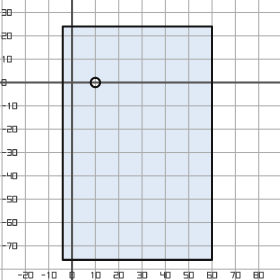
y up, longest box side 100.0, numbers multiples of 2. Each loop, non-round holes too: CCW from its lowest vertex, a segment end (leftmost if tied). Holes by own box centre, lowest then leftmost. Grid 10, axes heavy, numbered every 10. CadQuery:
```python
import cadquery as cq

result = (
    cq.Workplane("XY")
    .moveTo(-4.0, -76.0)
    .lineTo(60.0, -76.0)
    .lineTo(60.0, 24.0)
    .lineTo(-4.0, 24.0)
    .close()
    .moveTo(10.0, 0.0)
    .circle(2.0)
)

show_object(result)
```